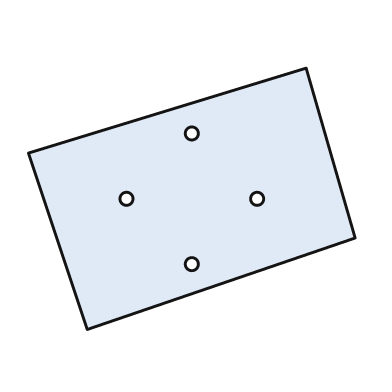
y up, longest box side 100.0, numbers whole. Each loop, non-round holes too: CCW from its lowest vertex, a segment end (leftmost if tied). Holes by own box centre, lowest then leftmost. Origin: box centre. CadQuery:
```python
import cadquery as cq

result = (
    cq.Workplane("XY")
    .moveTo(-32.0, -40.0)
    .lineTo(50.0, -12.0)
    .lineTo(35.0, 40.0)
    .lineTo(-50.0, 14.0)
    .close()
    .moveTo(0.0, -20.0)
    .circle(2.0)
    .moveTo(-20.0, 0.0)
    .circle(2.0)
    .moveTo(20.0, 0.0)
    .circle(2.0)
    .moveTo(0.0, 20.0)
    .circle(2.0)
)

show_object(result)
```